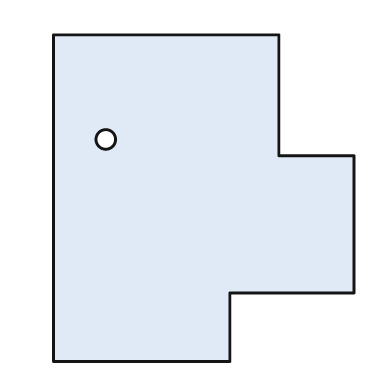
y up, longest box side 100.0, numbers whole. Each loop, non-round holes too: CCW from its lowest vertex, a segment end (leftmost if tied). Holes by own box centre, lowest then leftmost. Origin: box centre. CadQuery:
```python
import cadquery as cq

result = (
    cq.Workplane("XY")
    .moveTo(-46.0, -50.0)
    .lineTo(8.0, -50.0)
    .lineTo(8.0, -29.0)
    .lineTo(46.0, -29.0)
    .lineTo(46.0, 13.0)
    .lineTo(23.0, 13.0)
    .lineTo(23.0, 50.0)
    .lineTo(-46.0, 50.0)
    .close()
    .moveTo(-30.0, 18.0)
    .circle(3.0)
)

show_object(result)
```